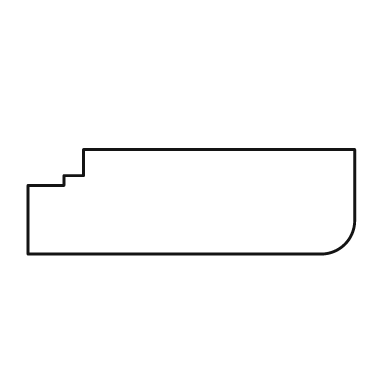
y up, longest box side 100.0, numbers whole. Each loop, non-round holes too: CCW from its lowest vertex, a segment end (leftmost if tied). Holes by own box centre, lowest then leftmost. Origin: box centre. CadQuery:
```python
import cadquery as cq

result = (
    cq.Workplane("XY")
    .moveTo(-50.0, -16.0)
    .lineTo(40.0, -16.0)
    .threePointArc((47.0, -13.0), (50.0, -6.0))
    .lineTo(50.0, 16.0)
    .lineTo(-33.0, 16.0)
    .lineTo(-33.0, 8.0)
    .lineTo(-39.0, 8.0)
    .lineTo(-39.0, 5.0)
    .lineTo(-50.0, 5.0)
    .close()
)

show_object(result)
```